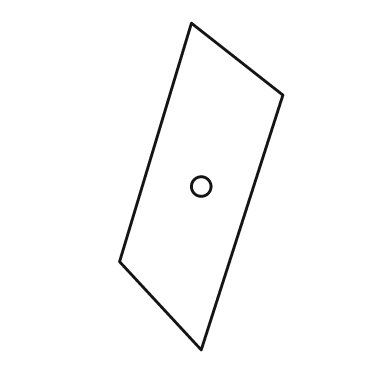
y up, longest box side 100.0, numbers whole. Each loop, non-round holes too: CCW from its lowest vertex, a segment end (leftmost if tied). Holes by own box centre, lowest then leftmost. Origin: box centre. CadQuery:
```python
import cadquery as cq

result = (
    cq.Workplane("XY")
    .moveTo(0.0, -50.0)
    .lineTo(25.0, 28.0)
    .lineTo(-3.0, 50.0)
    .lineTo(-25.0, -23.0)
    .close()
    .moveTo(0.0, 0.0)
    .circle(3.0)
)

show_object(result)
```